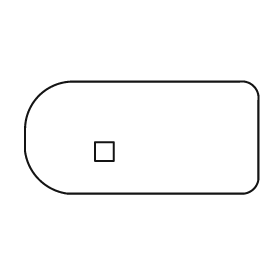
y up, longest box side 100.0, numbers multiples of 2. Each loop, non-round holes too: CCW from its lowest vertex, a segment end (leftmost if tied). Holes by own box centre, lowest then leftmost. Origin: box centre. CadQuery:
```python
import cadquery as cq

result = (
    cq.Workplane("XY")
    .moveTo(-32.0, -24.0)
    .lineTo(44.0, -24.0)
    .threePointArc((48.0, -22.0), (50.0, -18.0))
    .lineTo(50.0, 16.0)
    .threePointArc((48.0, 22.0), (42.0, 24.0))
    .lineTo(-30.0, 24.0)
    .threePointArc((-44.0, 18.0), (-50.0, 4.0))
    .lineTo(-50.0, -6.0)
    .threePointArc((-44.0, -18.0), (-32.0, -24.0))
    .close()
    .moveTo(-20.0, -10.0)
    .lineTo(-12.0, -10.0)
    .lineTo(-12.0, -2.0)
    .lineTo(-20.0, -2.0)
    .close()
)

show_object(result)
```